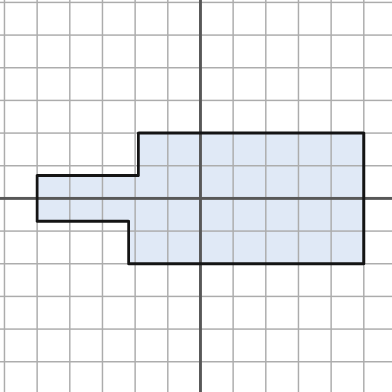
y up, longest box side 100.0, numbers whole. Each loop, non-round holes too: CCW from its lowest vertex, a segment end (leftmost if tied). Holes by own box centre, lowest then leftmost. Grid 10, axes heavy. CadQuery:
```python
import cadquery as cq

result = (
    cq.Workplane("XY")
    .moveTo(-22.0, -20.0)
    .lineTo(50.0, -20.0)
    .lineTo(50.0, 20.0)
    .lineTo(-19.0, 20.0)
    .lineTo(-19.0, 7.0)
    .lineTo(-50.0, 7.0)
    .lineTo(-50.0, -7.0)
    .lineTo(-22.0, -7.0)
    .close()
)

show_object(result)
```